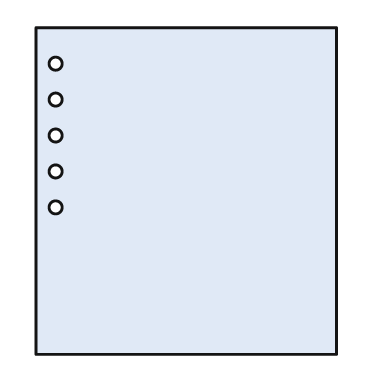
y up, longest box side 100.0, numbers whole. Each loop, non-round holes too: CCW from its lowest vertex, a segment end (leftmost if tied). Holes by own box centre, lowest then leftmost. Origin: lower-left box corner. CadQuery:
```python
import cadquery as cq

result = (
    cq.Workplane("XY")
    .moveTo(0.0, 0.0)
    .lineTo(92.0, 0.0)
    .lineTo(92.0, 100.0)
    .lineTo(0.0, 100.0)
    .close()
    .moveTo(6.0, 45.0)
    .circle(2.0)
    .moveTo(6.0, 56.0)
    .circle(2.0)
    .moveTo(6.0, 67.0)
    .circle(2.0)
    .moveTo(6.0, 78.0)
    .circle(2.0)
    .moveTo(6.0, 89.0)
    .circle(2.0)
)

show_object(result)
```